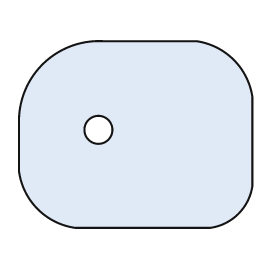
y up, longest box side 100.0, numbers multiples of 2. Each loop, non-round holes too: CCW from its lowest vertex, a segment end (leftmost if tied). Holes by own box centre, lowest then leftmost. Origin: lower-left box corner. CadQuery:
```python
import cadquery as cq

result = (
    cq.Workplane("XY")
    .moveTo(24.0, 0.0)
    .lineTo(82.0, 0.0)
    .threePointArc((94.0, 6.0), (100.0, 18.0))
    .lineTo(100.0, 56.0)
    .threePointArc((92.0, 72.0), (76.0, 80.0))
    .lineTo(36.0, 80.0)
    .threePointArc((10.0, 70.0), (0.0, 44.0))
    .lineTo(0.0, 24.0)
    .threePointArc((8.0, 8.0), (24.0, 0.0))
    .close()
    .moveTo(34.0, 42.0)
    .circle(6.0)
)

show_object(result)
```